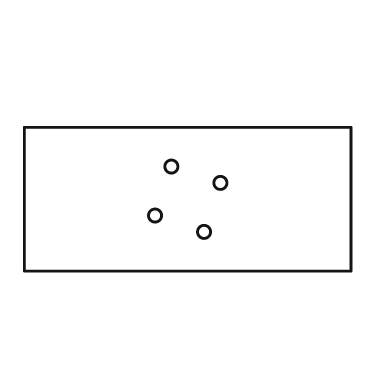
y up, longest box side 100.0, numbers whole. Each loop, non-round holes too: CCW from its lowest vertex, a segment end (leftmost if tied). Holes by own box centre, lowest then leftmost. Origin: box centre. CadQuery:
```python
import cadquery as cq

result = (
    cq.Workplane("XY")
    .moveTo(-50.0, -22.0)
    .lineTo(50.0, -22.0)
    .lineTo(50.0, 22.0)
    .lineTo(-50.0, 22.0)
    .close()
    .moveTo(5.0, -10.0)
    .circle(2.0)
    .moveTo(-10.0, -5.0)
    .circle(2.0)
    .moveTo(10.0, 5.0)
    .circle(2.0)
    .moveTo(-5.0, 10.0)
    .circle(2.0)
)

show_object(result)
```